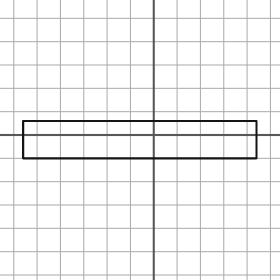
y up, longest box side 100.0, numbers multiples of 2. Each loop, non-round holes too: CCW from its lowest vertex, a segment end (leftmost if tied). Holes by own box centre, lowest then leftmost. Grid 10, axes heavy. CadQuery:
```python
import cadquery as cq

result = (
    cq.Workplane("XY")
    .moveTo(-56.0, -10.0)
    .lineTo(44.0, -10.0)
    .lineTo(44.0, 6.0)
    .lineTo(-56.0, 6.0)
    .close()
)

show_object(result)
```